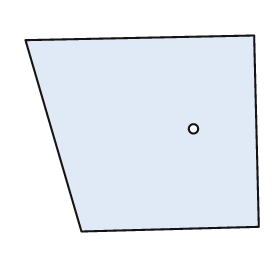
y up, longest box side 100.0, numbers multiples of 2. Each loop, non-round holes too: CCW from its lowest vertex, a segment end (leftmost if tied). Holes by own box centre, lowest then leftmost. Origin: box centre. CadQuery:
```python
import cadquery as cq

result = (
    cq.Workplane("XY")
    .moveTo(-26.0, -42.0)
    .lineTo(50.0, -40.0)
    .lineTo(48.0, 42.0)
    .lineTo(-50.0, 40.0)
    .close()
    .moveTo(22.0, 2.0)
    .circle(2.0)
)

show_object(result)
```